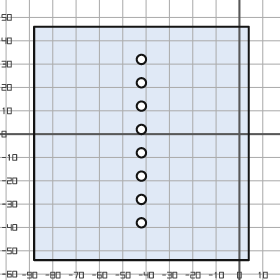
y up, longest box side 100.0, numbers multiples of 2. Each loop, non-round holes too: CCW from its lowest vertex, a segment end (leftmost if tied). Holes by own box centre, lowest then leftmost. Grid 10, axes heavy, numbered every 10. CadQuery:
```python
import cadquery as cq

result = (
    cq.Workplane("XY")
    .moveTo(-88.0, -54.0)
    .lineTo(4.0, -54.0)
    .lineTo(4.0, 46.0)
    .lineTo(-88.0, 46.0)
    .close()
    .moveTo(-42.0, -38.0)
    .circle(2.0)
    .moveTo(-42.0, -28.0)
    .circle(2.0)
    .moveTo(-42.0, -18.0)
    .circle(2.0)
    .moveTo(-42.0, -8.0)
    .circle(2.0)
    .moveTo(-42.0, 2.0)
    .circle(2.0)
    .moveTo(-42.0, 12.0)
    .circle(2.0)
    .moveTo(-42.0, 22.0)
    .circle(2.0)
    .moveTo(-42.0, 32.0)
    .circle(2.0)
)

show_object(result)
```